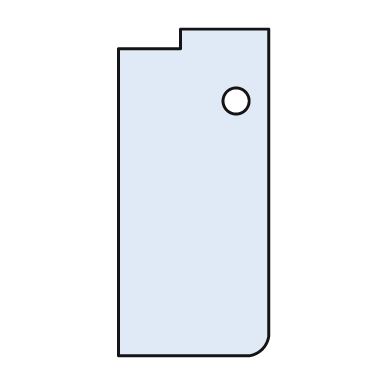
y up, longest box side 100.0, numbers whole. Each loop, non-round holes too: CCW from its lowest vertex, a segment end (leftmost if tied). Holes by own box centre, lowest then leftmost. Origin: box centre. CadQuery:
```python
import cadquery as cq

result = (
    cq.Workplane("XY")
    .moveTo(-23.0, -50.0)
    .lineTo(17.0, -50.0)
    .threePointArc((21.0, -48.0), (23.0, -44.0))
    .lineTo(23.0, 50.0)
    .lineTo(-4.0, 50.0)
    .lineTo(-4.0, 44.0)
    .lineTo(-23.0, 44.0)
    .close()
    .moveTo(13.0, 28.0)
    .circle(4.0)
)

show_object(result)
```